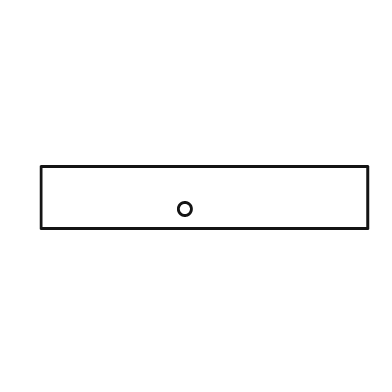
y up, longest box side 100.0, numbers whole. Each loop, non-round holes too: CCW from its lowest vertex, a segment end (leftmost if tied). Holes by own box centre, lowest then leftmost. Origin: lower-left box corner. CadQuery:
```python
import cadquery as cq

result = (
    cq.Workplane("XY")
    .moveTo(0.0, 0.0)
    .lineTo(100.0, 0.0)
    .lineTo(100.0, 19.0)
    .lineTo(0.0, 19.0)
    .close()
    .moveTo(44.0, 6.0)
    .circle(2.0)
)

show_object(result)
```